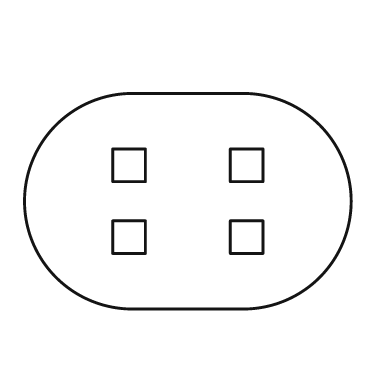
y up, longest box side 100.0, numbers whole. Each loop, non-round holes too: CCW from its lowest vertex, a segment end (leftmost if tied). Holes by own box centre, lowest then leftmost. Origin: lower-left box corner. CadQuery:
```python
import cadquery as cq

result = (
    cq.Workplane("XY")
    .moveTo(33.0, 0.0)
    .lineTo(67.0, 0.0)
    .threePointArc((100.0, 33.0), (67.0, 66.0))
    .lineTo(33.0, 66.0)
    .threePointArc((0.0, 33.0), (33.0, 0.0))
    .close()
    .moveTo(27.0, 17.0)
    .lineTo(37.0, 17.0)
    .lineTo(37.0, 27.0)
    .lineTo(27.0, 27.0)
    .close()
    .moveTo(63.0, 17.0)
    .lineTo(73.0, 17.0)
    .lineTo(73.0, 27.0)
    .lineTo(63.0, 27.0)
    .close()
    .moveTo(27.0, 39.0)
    .lineTo(37.0, 39.0)
    .lineTo(37.0, 49.0)
    .lineTo(27.0, 49.0)
    .close()
    .moveTo(63.0, 39.0)
    .lineTo(73.0, 39.0)
    .lineTo(73.0, 49.0)
    .lineTo(63.0, 49.0)
    .close()
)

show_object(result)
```